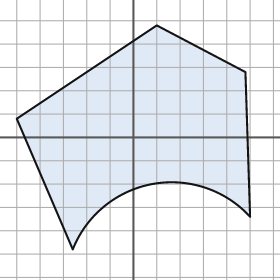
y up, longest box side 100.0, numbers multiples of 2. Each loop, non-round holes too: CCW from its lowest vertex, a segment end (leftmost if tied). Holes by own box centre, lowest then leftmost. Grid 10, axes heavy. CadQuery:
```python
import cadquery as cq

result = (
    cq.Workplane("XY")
    .moveTo(-26.0, -48.0)
    .threePointArc((8.0, -20.0), (50.0, -34.0))
    .lineTo(48.0, 28.0)
    .lineTo(10.0, 48.0)
    .lineTo(-50.0, 8.0)
    .close()
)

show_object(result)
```